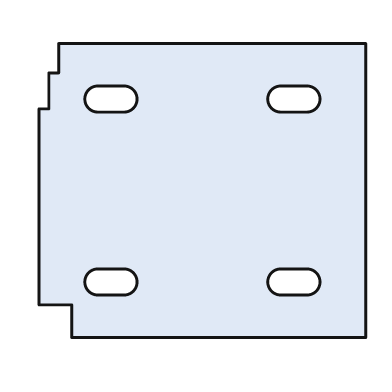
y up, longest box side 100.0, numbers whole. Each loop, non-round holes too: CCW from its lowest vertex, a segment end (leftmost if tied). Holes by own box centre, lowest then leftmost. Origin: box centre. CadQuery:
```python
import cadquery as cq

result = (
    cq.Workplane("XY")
    .moveTo(-40.0, -45.0)
    .lineTo(50.0, -45.0)
    .lineTo(50.0, 45.0)
    .lineTo(-44.0, 45.0)
    .lineTo(-44.0, 36.0)
    .lineTo(-47.0, 36.0)
    .lineTo(-47.0, 25.0)
    .lineTo(-50.0, 25.0)
    .lineTo(-50.0, -35.0)
    .lineTo(-40.0, -35.0)
    .close()
    .moveTo(-32.0, -32.0)
    .lineTo(-24.0, -32.0)
    .threePointArc((-20.0, -28.0), (-24.0, -24.0))
    .lineTo(-32.0, -24.0)
    .threePointArc((-36.0, -28.0), (-32.0, -32.0))
    .close()
    .moveTo(24.0, -32.0)
    .lineTo(32.0, -32.0)
    .threePointArc((36.0, -28.0), (32.0, -24.0))
    .lineTo(24.0, -24.0)
    .threePointArc((20.0, -28.0), (24.0, -32.0))
    .close()
    .moveTo(-32.0, 24.0)
    .lineTo(-24.0, 24.0)
    .threePointArc((-20.0, 28.0), (-24.0, 32.0))
    .lineTo(-32.0, 32.0)
    .threePointArc((-36.0, 28.0), (-32.0, 24.0))
    .close()
    .moveTo(24.0, 24.0)
    .lineTo(32.0, 24.0)
    .threePointArc((36.0, 28.0), (32.0, 32.0))
    .lineTo(24.0, 32.0)
    .threePointArc((20.0, 28.0), (24.0, 24.0))
    .close()
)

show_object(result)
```